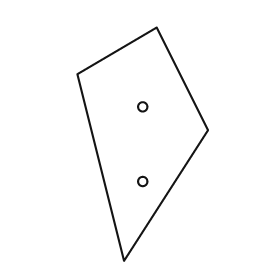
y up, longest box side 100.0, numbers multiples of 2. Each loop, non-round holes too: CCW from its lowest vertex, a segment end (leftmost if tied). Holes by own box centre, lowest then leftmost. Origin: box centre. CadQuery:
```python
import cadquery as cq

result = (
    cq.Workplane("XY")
    .moveTo(-8.0, -50.0)
    .lineTo(28.0, 6.0)
    .lineTo(6.0, 50.0)
    .lineTo(-28.0, 30.0)
    .close()
    .moveTo(0.0, -16.0)
    .circle(2.0)
    .moveTo(0.0, 16.0)
    .circle(2.0)
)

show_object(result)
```